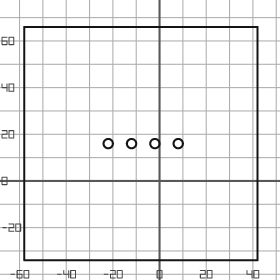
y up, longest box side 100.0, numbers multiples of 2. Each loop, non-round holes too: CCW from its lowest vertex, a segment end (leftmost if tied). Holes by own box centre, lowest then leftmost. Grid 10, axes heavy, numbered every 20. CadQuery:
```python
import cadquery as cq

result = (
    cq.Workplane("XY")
    .moveTo(-58.0, -34.0)
    .lineTo(42.0, -34.0)
    .lineTo(42.0, 66.0)
    .lineTo(-58.0, 66.0)
    .close()
    .moveTo(-22.0, 16.0)
    .circle(2.0)
    .moveTo(-12.0, 16.0)
    .circle(2.0)
    .moveTo(-2.0, 16.0)
    .circle(2.0)
    .moveTo(8.0, 16.0)
    .circle(2.0)
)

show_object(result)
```